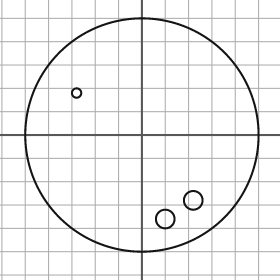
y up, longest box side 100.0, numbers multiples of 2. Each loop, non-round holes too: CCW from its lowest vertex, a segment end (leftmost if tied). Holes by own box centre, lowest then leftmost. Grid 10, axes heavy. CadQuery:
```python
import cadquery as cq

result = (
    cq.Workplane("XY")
    .moveTo(0.0, 0.0)
    .circle(50.0)
    .moveTo(10.0, -36.0)
    .circle(4.0)
    .moveTo(22.0, -28.0)
    .circle(4.0)
    .moveTo(-28.0, 18.0)
    .circle(2.0)
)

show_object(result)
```